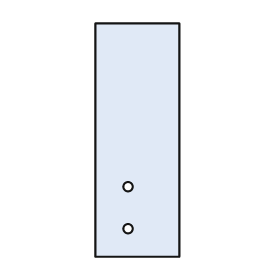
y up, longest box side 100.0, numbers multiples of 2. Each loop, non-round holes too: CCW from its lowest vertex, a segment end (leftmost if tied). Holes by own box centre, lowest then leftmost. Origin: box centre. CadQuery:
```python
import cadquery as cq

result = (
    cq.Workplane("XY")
    .moveTo(-18.0, -50.0)
    .lineTo(18.0, -50.0)
    .lineTo(18.0, 50.0)
    .lineTo(-18.0, 50.0)
    .close()
    .moveTo(-4.0, -38.0)
    .circle(2.0)
    .moveTo(-4.0, -20.0)
    .circle(2.0)
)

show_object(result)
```